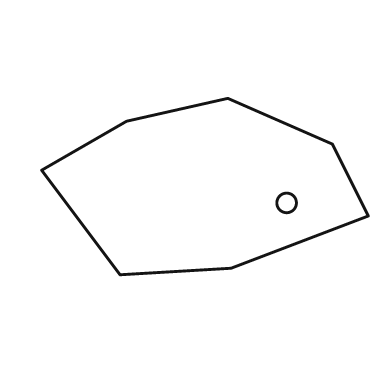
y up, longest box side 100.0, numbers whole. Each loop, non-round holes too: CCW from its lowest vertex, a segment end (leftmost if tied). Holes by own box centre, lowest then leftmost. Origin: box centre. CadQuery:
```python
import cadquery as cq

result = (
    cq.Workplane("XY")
    .moveTo(-26.0, -27.0)
    .lineTo(8.0, -25.0)
    .lineTo(50.0, -9.0)
    .lineTo(39.0, 13.0)
    .lineTo(7.0, 27.0)
    .lineTo(-24.0, 20.0)
    .lineTo(-50.0, 5.0)
    .close()
    .moveTo(25.0, -5.0)
    .circle(3.0)
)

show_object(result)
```